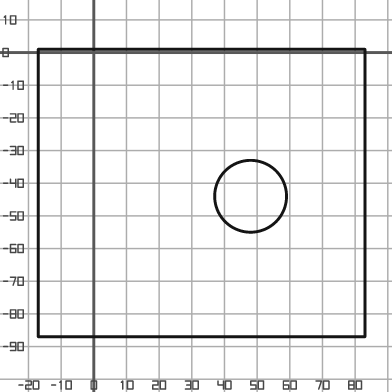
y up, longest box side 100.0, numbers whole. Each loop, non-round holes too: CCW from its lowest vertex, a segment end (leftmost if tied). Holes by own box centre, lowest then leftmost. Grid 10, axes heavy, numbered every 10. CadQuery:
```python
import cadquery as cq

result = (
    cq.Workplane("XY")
    .moveTo(-17.0, -87.0)
    .lineTo(83.0, -87.0)
    .lineTo(83.0, 1.0)
    .lineTo(-17.0, 1.0)
    .close()
    .moveTo(48.0, -44.0)
    .circle(11.0)
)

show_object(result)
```